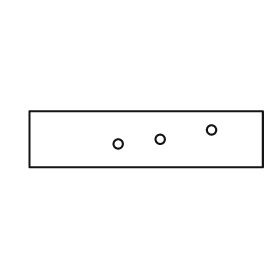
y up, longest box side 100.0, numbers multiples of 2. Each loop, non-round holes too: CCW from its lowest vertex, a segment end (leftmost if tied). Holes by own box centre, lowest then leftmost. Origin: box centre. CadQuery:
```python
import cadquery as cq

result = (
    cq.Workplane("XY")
    .moveTo(-50.0, -12.0)
    .lineTo(50.0, -12.0)
    .lineTo(50.0, 12.0)
    .lineTo(-50.0, 12.0)
    .close()
    .moveTo(-12.0, -2.0)
    .circle(2.0)
    .moveTo(6.0, 0.0)
    .circle(2.0)
    .moveTo(28.0, 4.0)
    .circle(2.0)
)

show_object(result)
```